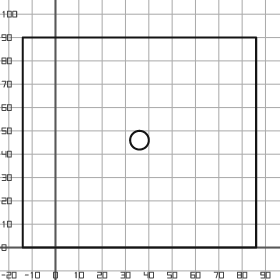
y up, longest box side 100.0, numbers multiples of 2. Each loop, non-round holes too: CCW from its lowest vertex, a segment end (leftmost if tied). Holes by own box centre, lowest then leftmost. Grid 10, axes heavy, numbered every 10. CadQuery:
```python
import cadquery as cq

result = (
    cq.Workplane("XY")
    .moveTo(-14.0, 0.0)
    .lineTo(86.0, 0.0)
    .lineTo(86.0, 90.0)
    .lineTo(-14.0, 90.0)
    .close()
    .moveTo(36.0, 46.0)
    .circle(4.0)
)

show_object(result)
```